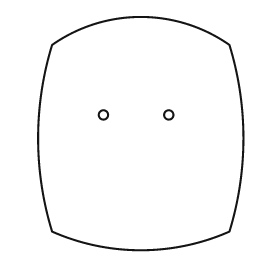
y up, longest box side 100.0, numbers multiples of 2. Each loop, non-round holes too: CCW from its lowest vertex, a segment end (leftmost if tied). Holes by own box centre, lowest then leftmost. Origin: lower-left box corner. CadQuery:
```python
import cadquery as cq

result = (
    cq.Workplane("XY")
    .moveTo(6.0, 8.0)
    .threePointArc((44.0, 0.0), (82.0, 8.0))
    .threePointArc((88.0, 48.0), (82.0, 88.0))
    .threePointArc((44.0, 100.0), (6.0, 88.0))
    .threePointArc((0.0, 48.0), (6.0, 8.0))
    .close()
    .moveTo(28.0, 58.0)
    .circle(2.0)
    .moveTo(56.0, 58.0)
    .circle(2.0)
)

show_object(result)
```